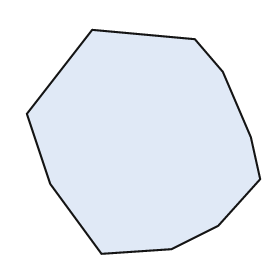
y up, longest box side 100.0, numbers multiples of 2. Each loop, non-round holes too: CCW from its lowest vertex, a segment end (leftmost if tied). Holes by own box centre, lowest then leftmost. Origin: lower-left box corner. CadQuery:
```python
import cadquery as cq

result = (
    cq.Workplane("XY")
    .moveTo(32.0, 0.0)
    .lineTo(62.0, 2.0)
    .lineTo(82.0, 12.0)
    .lineTo(100.0, 32.0)
    .lineTo(96.0, 50.0)
    .lineTo(84.0, 78.0)
    .lineTo(72.0, 92.0)
    .lineTo(28.0, 96.0)
    .lineTo(0.0, 60.0)
    .lineTo(10.0, 30.0)
    .close()
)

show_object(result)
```